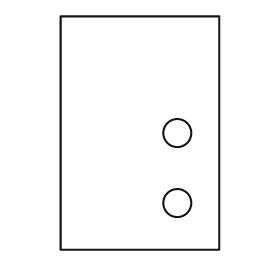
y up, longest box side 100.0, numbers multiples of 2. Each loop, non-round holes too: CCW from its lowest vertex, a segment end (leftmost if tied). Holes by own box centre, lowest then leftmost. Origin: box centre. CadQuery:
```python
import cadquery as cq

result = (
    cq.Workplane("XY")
    .moveTo(-34.0, -50.0)
    .lineTo(34.0, -50.0)
    .lineTo(34.0, 50.0)
    .lineTo(-34.0, 50.0)
    .close()
    .moveTo(16.0, -30.0)
    .circle(6.0)
    .moveTo(16.0, 0.0)
    .circle(6.0)
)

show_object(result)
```